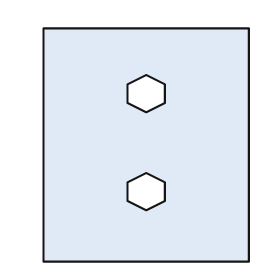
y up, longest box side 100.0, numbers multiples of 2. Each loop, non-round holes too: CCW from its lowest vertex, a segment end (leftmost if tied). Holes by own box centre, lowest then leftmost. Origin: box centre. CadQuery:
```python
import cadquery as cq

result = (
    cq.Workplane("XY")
    .moveTo(-44.0, -50.0)
    .lineTo(44.0, -50.0)
    .lineTo(44.0, 50.0)
    .lineTo(-44.0, 50.0)
    .close()
    .moveTo(0.0, -28.0)
    .lineTo(8.0, -24.0)
    .lineTo(8.0, -16.0)
    .lineTo(0.0, -12.0)
    .lineTo(-8.0, -16.0)
    .lineTo(-8.0, -24.0)
    .close()
    .moveTo(0.0, 14.0)
    .lineTo(8.0, 18.0)
    .lineTo(8.0, 26.0)
    .lineTo(0.0, 30.0)
    .lineTo(-8.0, 26.0)
    .lineTo(-8.0, 18.0)
    .close()
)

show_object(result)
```